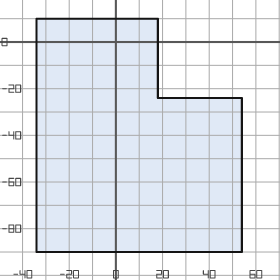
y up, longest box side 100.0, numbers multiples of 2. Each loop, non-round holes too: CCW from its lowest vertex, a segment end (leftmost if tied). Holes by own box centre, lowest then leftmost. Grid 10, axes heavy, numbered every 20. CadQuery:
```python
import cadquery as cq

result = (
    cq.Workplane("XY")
    .moveTo(-34.0, -90.0)
    .lineTo(54.0, -90.0)
    .lineTo(54.0, -24.0)
    .lineTo(18.0, -24.0)
    .lineTo(18.0, 10.0)
    .lineTo(-34.0, 10.0)
    .close()
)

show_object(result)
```